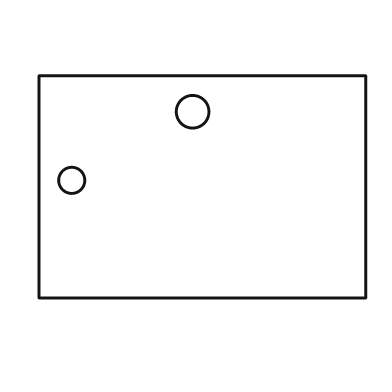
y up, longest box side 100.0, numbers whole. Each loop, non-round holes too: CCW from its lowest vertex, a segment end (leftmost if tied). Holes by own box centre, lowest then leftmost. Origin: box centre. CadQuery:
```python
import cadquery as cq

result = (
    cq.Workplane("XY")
    .moveTo(-50.0, -34.0)
    .lineTo(50.0, -34.0)
    .lineTo(50.0, 34.0)
    .lineTo(-50.0, 34.0)
    .close()
    .moveTo(-40.0, 2.0)
    .circle(4.0)
    .moveTo(-3.0, 23.0)
    .circle(5.0)
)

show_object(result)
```